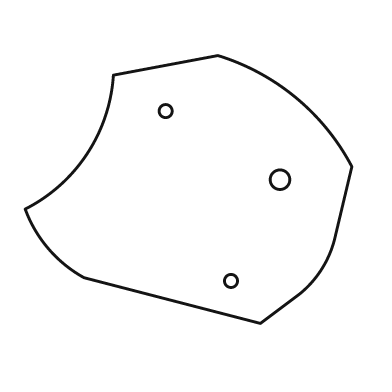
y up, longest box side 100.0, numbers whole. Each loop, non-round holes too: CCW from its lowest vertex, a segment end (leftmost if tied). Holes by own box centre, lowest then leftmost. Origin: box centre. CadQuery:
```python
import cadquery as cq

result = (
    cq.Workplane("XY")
    .moveTo(22.0, -41.0)
    .lineTo(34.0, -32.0)
    .threePointArc((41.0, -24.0), (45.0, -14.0))
    .lineTo(50.0, 7.0)
    .threePointArc((33.0, 28.0), (9.0, 41.0))
    .lineTo(-23.0, 35.0)
    .threePointArc((-31.0, 11.0), (-50.0, -6.0))
    .threePointArc((-43.0, -18.0), (-32.0, -27.0))
    .close()
    .moveTo(13.0, -28.0)
    .circle(2.0)
    .moveTo(28.0, 3.0)
    .circle(3.0)
    .moveTo(-7.0, 24.0)
    .circle(2.0)
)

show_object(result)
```